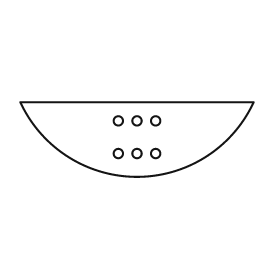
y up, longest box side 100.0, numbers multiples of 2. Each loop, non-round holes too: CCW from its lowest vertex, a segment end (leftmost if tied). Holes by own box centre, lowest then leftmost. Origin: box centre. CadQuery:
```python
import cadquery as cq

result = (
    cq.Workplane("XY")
    .moveTo(-50.0, 16.0)
    .threePointArc((0.0, -16.0), (50.0, 16.0))
    .close()
    .moveTo(-8.0, -6.0)
    .circle(2.0)
    .moveTo(0.0, -6.0)
    .circle(2.0)
    .moveTo(8.0, -6.0)
    .circle(2.0)
    .moveTo(-8.0, 8.0)
    .circle(2.0)
    .moveTo(0.0, 8.0)
    .circle(2.0)
    .moveTo(8.0, 8.0)
    .circle(2.0)
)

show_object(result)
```